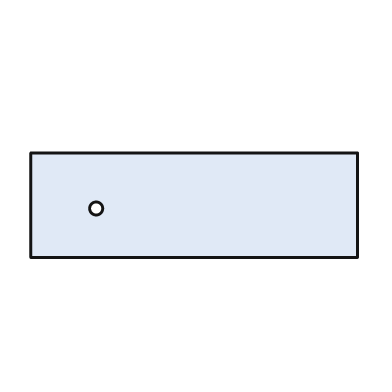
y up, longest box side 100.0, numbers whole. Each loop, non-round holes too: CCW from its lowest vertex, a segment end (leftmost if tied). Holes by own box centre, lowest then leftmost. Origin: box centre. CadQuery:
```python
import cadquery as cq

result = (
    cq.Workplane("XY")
    .moveTo(-50.0, -16.0)
    .lineTo(50.0, -16.0)
    .lineTo(50.0, 16.0)
    .lineTo(-50.0, 16.0)
    .close()
    .moveTo(-30.0, -1.0)
    .circle(2.0)
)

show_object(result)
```